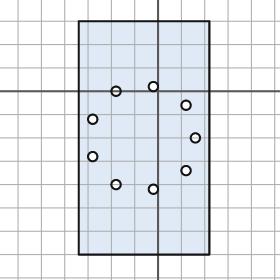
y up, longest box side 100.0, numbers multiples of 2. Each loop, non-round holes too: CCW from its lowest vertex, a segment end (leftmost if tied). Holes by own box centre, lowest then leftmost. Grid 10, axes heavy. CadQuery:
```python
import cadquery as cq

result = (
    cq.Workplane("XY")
    .moveTo(-34.0, -70.0)
    .lineTo(22.0, -70.0)
    .lineTo(22.0, 30.0)
    .lineTo(-34.0, 30.0)
    .close()
    .moveTo(-2.0, -42.0)
    .circle(2.0)
    .moveTo(-18.0, -40.0)
    .circle(2.0)
    .moveTo(12.0, -34.0)
    .circle(2.0)
    .moveTo(-28.0, -28.0)
    .circle(2.0)
    .moveTo(16.0, -20.0)
    .circle(2.0)
    .moveTo(-28.0, -12.0)
    .circle(2.0)
    .moveTo(12.0, -6.0)
    .circle(2.0)
    .moveTo(-18.0, 0.0)
    .circle(2.0)
    .moveTo(-2.0, 2.0)
    .circle(2.0)
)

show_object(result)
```